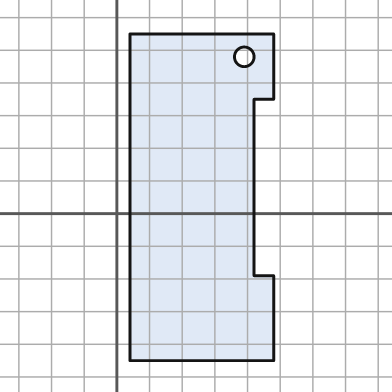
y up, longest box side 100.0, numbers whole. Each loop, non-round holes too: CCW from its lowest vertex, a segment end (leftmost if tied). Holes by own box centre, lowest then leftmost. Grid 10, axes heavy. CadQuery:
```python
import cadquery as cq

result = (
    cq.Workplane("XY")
    .moveTo(4.0, -45.0)
    .lineTo(48.0, -45.0)
    .lineTo(48.0, -19.0)
    .lineTo(42.0, -19.0)
    .lineTo(42.0, 35.0)
    .lineTo(48.0, 35.0)
    .lineTo(48.0, 55.0)
    .lineTo(4.0, 55.0)
    .close()
    .moveTo(39.0, 48.0)
    .circle(3.0)
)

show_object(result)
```